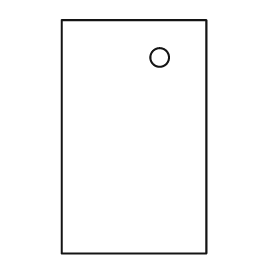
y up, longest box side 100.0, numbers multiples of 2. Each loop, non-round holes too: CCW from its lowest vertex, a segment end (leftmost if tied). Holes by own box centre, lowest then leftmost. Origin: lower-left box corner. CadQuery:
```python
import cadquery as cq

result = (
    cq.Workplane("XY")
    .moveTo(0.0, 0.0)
    .lineTo(62.0, 0.0)
    .lineTo(62.0, 100.0)
    .lineTo(0.0, 100.0)
    .close()
    .moveTo(42.0, 84.0)
    .circle(4.0)
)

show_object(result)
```